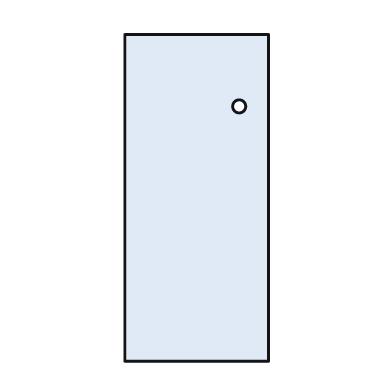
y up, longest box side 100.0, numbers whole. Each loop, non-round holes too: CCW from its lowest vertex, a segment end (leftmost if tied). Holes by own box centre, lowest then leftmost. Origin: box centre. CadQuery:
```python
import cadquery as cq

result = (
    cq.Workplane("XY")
    .moveTo(-22.0, -50.0)
    .lineTo(22.0, -50.0)
    .lineTo(22.0, 50.0)
    .lineTo(-22.0, 50.0)
    .close()
    .moveTo(13.0, 28.0)
    .circle(2.0)
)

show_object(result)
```